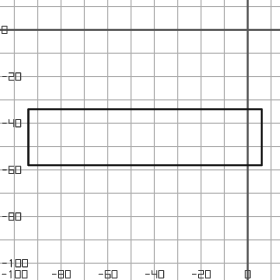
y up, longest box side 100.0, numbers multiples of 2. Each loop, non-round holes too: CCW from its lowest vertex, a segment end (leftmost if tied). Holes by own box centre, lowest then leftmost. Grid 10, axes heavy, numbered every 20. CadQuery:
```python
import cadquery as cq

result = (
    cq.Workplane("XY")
    .moveTo(-94.0, -58.0)
    .lineTo(6.0, -58.0)
    .lineTo(6.0, -34.0)
    .lineTo(-94.0, -34.0)
    .close()
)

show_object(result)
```